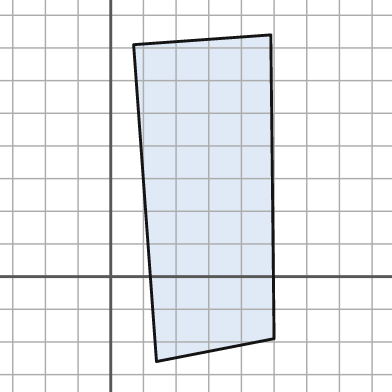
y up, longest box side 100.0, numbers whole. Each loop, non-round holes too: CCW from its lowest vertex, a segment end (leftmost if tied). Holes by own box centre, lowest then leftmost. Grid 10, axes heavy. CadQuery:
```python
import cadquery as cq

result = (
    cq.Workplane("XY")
    .moveTo(14.0, -26.0)
    .lineTo(50.0, -19.0)
    .lineTo(49.0, 74.0)
    .lineTo(7.0, 71.0)
    .close()
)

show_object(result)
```